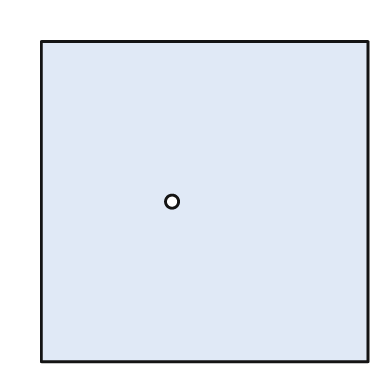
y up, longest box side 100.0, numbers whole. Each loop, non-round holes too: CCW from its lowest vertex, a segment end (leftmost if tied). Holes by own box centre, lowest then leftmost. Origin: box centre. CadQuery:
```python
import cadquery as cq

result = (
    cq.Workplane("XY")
    .moveTo(-50.0, -49.0)
    .lineTo(50.0, -49.0)
    .lineTo(50.0, 49.0)
    .lineTo(-50.0, 49.0)
    .close()
    .moveTo(-10.0, 0.0)
    .circle(2.0)
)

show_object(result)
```